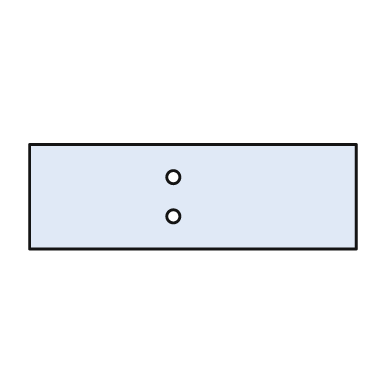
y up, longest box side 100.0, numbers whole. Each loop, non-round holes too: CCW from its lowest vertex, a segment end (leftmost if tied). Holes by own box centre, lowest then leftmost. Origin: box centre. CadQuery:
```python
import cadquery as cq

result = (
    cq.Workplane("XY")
    .moveTo(-50.0, -16.0)
    .lineTo(50.0, -16.0)
    .lineTo(50.0, 16.0)
    .lineTo(-50.0, 16.0)
    .close()
    .moveTo(-6.0, -6.0)
    .circle(2.0)
    .moveTo(-6.0, 6.0)
    .circle(2.0)
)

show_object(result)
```